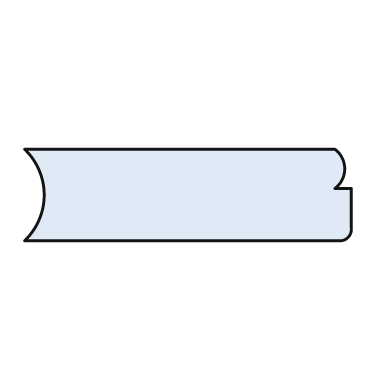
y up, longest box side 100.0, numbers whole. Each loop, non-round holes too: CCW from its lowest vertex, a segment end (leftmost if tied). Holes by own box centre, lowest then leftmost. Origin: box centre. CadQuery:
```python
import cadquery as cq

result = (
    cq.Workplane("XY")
    .moveTo(-50.0, -14.0)
    .lineTo(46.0, -14.0)
    .threePointArc((49.0, -13.0), (50.0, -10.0))
    .lineTo(50.0, 2.0)
    .lineTo(45.0, 2.0)
    .threePointArc((48.0, 8.0), (45.0, 14.0))
    .lineTo(-50.0, 14.0)
    .threePointArc((-44.0, 0.0), (-50.0, -14.0))
    .close()
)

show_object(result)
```